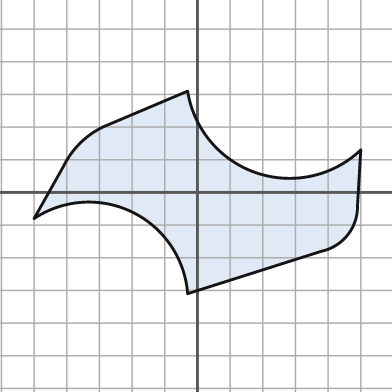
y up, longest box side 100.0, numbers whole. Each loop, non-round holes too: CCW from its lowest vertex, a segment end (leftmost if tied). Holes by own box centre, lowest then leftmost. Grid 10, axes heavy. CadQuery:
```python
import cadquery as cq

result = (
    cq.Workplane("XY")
    .moveTo(-3.0, -31.0)
    .lineTo(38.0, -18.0)
    .threePointArc((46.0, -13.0), (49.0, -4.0))
    .lineTo(50.0, 13.0)
    .threePointArc((18.0, 6.0), (-3.0, 31.0))
    .lineTo(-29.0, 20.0)
    .threePointArc((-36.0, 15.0), (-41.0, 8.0))
    .lineTo(-50.0, -8.0)
    .threePointArc((-20.0, -6.0), (-3.0, -31.0))
    .close()
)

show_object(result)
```